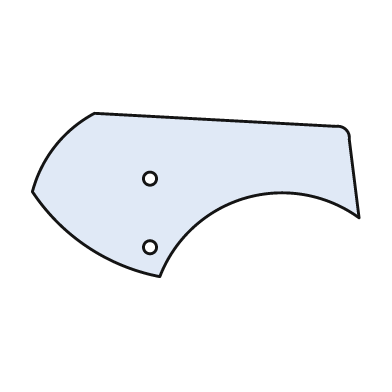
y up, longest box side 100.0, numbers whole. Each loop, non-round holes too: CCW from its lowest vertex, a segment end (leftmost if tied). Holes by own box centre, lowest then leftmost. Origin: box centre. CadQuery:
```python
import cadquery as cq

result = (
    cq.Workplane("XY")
    .moveTo(-11.0, -25.0)
    .threePointArc((15.0, -1.0), (50.0, -7.0))
    .lineTo(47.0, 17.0)
    .threePointArc((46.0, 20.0), (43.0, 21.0))
    .lineTo(-31.0, 25.0)
    .threePointArc((-43.0, 15.0), (-50.0, 1.0))
    .threePointArc((-33.0, -16.0), (-11.0, -25.0))
    .close()
    .moveTo(-14.0, -16.0)
    .circle(2.0)
    .moveTo(-14.0, 5.0)
    .circle(2.0)
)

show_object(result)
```